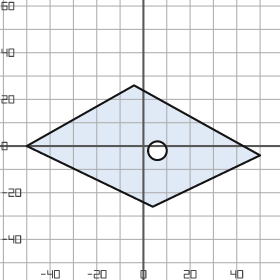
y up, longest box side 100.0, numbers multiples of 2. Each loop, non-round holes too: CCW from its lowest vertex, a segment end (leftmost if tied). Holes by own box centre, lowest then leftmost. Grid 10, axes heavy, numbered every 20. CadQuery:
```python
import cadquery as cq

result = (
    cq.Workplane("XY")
    .moveTo(4.0, -26.0)
    .lineTo(50.0, -4.0)
    .lineTo(-4.0, 26.0)
    .lineTo(-50.0, 0.0)
    .close()
    .moveTo(6.0, -2.0)
    .circle(4.0)
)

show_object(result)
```